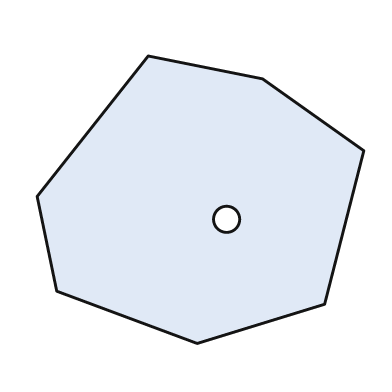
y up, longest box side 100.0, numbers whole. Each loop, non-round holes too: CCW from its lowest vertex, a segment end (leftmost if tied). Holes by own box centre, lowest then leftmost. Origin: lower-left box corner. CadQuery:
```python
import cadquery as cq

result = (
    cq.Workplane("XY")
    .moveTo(49.0, 0.0)
    .lineTo(88.0, 12.0)
    .lineTo(100.0, 59.0)
    .lineTo(69.0, 81.0)
    .lineTo(34.0, 88.0)
    .lineTo(0.0, 45.0)
    .lineTo(6.0, 16.0)
    .close()
    .moveTo(58.0, 38.0)
    .circle(4.0)
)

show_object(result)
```